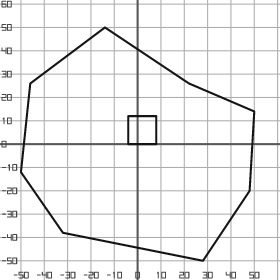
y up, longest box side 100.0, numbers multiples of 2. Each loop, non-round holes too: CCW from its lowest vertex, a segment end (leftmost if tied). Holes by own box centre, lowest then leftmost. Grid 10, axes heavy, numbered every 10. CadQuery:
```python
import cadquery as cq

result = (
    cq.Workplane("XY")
    .moveTo(28.0, -50.0)
    .lineTo(48.0, -20.0)
    .lineTo(50.0, 14.0)
    .lineTo(22.0, 26.0)
    .lineTo(-14.0, 50.0)
    .lineTo(-46.0, 26.0)
    .lineTo(-50.0, -12.0)
    .lineTo(-32.0, -38.0)
    .close()
    .moveTo(-4.0, 0.0)
    .lineTo(8.0, 0.0)
    .lineTo(8.0, 12.0)
    .lineTo(-4.0, 12.0)
    .close()
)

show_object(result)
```